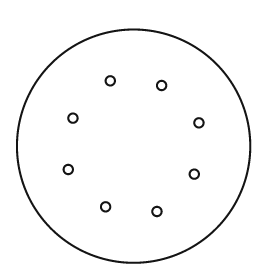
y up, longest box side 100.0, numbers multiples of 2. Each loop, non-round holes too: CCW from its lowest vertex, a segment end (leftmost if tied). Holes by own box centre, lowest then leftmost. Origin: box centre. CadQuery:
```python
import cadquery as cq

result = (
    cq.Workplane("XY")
    .moveTo(0.0, 0.0)
    .circle(50.0)
    .moveTo(10.0, -28.0)
    .circle(2.0)
    .moveTo(-12.0, -26.0)
    .circle(2.0)
    .moveTo(26.0, -12.0)
    .circle(2.0)
    .moveTo(-28.0, -10.0)
    .circle(2.0)
    .moveTo(28.0, 10.0)
    .circle(2.0)
    .moveTo(-26.0, 12.0)
    .circle(2.0)
    .moveTo(12.0, 26.0)
    .circle(2.0)
    .moveTo(-10.0, 28.0)
    .circle(2.0)
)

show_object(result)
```